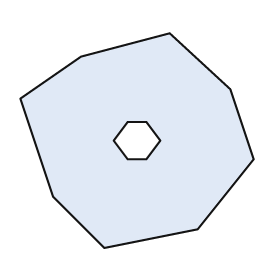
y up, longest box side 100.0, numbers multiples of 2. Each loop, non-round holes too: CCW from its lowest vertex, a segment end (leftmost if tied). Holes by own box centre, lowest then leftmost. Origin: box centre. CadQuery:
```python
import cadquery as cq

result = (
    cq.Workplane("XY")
    .moveTo(-14.0, -46.0)
    .lineTo(26.0, -38.0)
    .lineTo(50.0, -8.0)
    .lineTo(40.0, 22.0)
    .lineTo(14.0, 46.0)
    .lineTo(-24.0, 36.0)
    .lineTo(-50.0, 18.0)
    .lineTo(-36.0, -24.0)
    .close()
    .moveTo(-4.0, -8.0)
    .lineTo(4.0, -8.0)
    .lineTo(10.0, 0.0)
    .lineTo(4.0, 8.0)
    .lineTo(-4.0, 8.0)
    .lineTo(-10.0, 0.0)
    .close()
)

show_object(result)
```